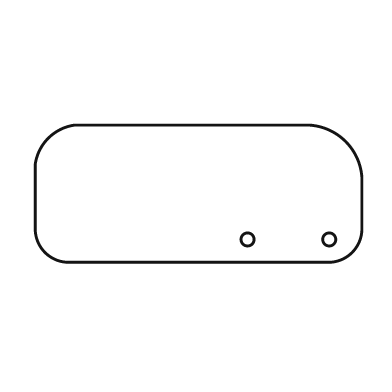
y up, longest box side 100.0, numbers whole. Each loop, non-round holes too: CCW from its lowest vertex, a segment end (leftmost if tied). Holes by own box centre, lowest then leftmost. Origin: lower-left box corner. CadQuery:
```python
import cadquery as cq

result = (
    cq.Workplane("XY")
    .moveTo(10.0, 0.0)
    .lineTo(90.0, 0.0)
    .threePointArc((97.0, 3.0), (100.0, 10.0))
    .lineTo(100.0, 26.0)
    .threePointArc((95.0, 37.0), (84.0, 42.0))
    .lineTo(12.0, 42.0)
    .threePointArc((4.0, 38.0), (0.0, 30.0))
    .lineTo(0.0, 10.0)
    .threePointArc((3.0, 3.0), (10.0, 0.0))
    .close()
    .moveTo(65.0, 7.0)
    .circle(2.0)
    .moveTo(90.0, 7.0)
    .circle(2.0)
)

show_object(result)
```